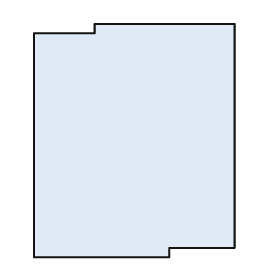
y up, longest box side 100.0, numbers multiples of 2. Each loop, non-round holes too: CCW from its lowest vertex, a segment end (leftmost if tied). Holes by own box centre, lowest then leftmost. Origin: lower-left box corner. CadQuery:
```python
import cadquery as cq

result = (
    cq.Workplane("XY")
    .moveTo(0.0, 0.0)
    .lineTo(58.0, 0.0)
    .lineTo(58.0, 4.0)
    .lineTo(86.0, 4.0)
    .lineTo(86.0, 100.0)
    .lineTo(26.0, 100.0)
    .lineTo(26.0, 96.0)
    .lineTo(0.0, 96.0)
    .close()
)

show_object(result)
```